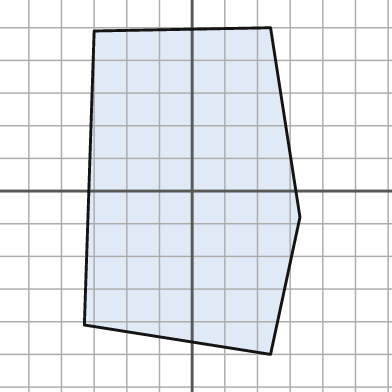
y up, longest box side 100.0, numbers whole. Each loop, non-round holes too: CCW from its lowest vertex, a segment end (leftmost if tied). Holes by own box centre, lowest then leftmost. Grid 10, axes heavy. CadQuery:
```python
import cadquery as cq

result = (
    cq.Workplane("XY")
    .moveTo(24.0, -50.0)
    .lineTo(33.0, -8.0)
    .lineTo(24.0, 50.0)
    .lineTo(-30.0, 49.0)
    .lineTo(-33.0, -41.0)
    .close()
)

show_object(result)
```